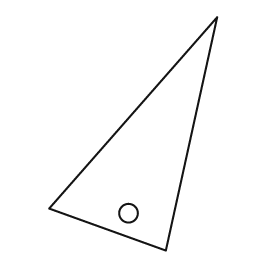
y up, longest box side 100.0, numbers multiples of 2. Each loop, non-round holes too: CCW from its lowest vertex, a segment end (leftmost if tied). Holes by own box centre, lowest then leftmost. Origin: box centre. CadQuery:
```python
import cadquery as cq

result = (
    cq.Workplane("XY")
    .moveTo(14.0, -50.0)
    .lineTo(36.0, 50.0)
    .lineTo(-36.0, -32.0)
    .close()
    .moveTo(-2.0, -34.0)
    .circle(4.0)
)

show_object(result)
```